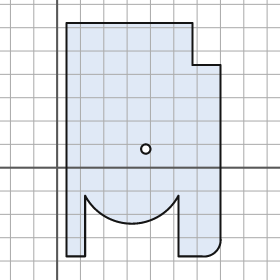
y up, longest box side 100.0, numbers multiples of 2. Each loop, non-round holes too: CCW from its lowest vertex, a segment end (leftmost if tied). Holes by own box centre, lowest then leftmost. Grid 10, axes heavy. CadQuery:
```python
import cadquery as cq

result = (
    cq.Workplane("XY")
    .moveTo(4.0, -38.0)
    .lineTo(12.0, -38.0)
    .lineTo(12.0, -12.0)
    .threePointArc((32.0, -24.0), (52.0, -12.0))
    .lineTo(52.0, -38.0)
    .lineTo(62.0, -38.0)
    .threePointArc((68.0, -36.0), (70.0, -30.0))
    .lineTo(70.0, 44.0)
    .lineTo(58.0, 44.0)
    .lineTo(58.0, 62.0)
    .lineTo(4.0, 62.0)
    .close()
    .moveTo(38.0, 8.0)
    .circle(2.0)
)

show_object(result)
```